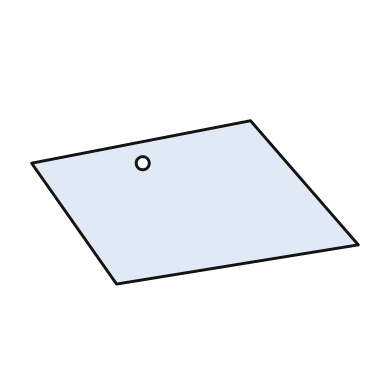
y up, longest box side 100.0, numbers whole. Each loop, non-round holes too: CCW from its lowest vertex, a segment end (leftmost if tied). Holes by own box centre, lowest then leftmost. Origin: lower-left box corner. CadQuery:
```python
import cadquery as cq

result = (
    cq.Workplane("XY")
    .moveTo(26.0, 0.0)
    .lineTo(100.0, 12.0)
    .lineTo(67.0, 50.0)
    .lineTo(0.0, 37.0)
    .close()
    .moveTo(34.0, 37.0)
    .circle(2.0)
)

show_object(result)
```